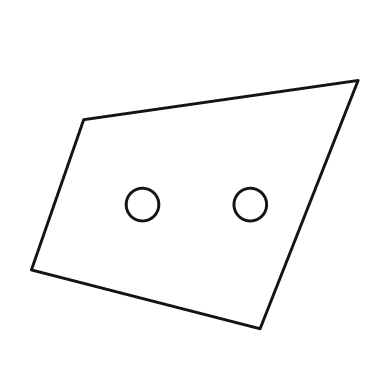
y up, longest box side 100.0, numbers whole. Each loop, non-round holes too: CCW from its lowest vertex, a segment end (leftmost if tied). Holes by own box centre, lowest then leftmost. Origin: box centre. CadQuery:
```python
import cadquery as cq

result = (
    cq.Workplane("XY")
    .moveTo(20.0, -38.0)
    .lineTo(50.0, 38.0)
    .lineTo(-34.0, 26.0)
    .lineTo(-50.0, -20.0)
    .close()
    .moveTo(-16.0, 0.0)
    .circle(5.0)
    .moveTo(17.0, 0.0)
    .circle(5.0)
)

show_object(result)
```